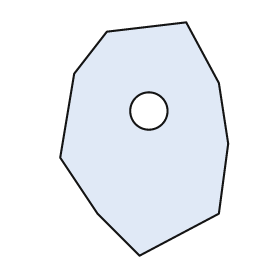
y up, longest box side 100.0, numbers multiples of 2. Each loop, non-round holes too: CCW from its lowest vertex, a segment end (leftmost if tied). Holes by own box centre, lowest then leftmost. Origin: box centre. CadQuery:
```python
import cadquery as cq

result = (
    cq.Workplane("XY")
    .moveTo(-2.0, -50.0)
    .lineTo(32.0, -32.0)
    .lineTo(36.0, -2.0)
    .lineTo(32.0, 24.0)
    .lineTo(18.0, 50.0)
    .lineTo(-16.0, 46.0)
    .lineTo(-30.0, 28.0)
    .lineTo(-36.0, -8.0)
    .lineTo(-20.0, -32.0)
    .close()
    .moveTo(2.0, 12.0)
    .circle(8.0)
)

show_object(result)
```